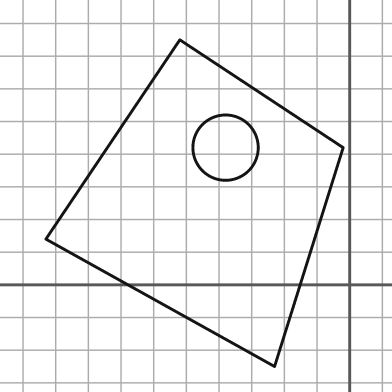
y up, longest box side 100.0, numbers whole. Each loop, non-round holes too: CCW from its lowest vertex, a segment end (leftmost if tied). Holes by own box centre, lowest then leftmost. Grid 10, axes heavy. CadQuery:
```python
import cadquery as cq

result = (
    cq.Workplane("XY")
    .moveTo(-23.0, -25.0)
    .lineTo(-2.0, 42.0)
    .lineTo(-52.0, 75.0)
    .lineTo(-93.0, 14.0)
    .close()
    .moveTo(-38.0, 42.0)
    .circle(10.0)
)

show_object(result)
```